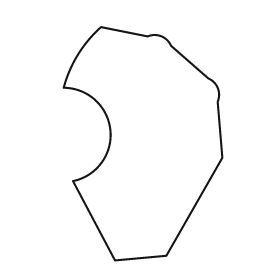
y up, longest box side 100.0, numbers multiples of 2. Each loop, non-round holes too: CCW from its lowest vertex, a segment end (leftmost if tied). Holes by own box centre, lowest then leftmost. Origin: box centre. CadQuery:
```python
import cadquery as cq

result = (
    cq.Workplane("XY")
    .moveTo(-12.0, -50.0)
    .lineTo(10.0, -48.0)
    .lineTo(34.0, -6.0)
    .lineTo(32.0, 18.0)
    .threePointArc((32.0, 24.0), (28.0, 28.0))
    .lineTo(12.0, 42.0)
    .threePointArc((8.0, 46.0), (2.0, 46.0))
    .lineTo(-18.0, 50.0)
    .threePointArc((-28.0, 38.0), (-34.0, 24.0))
    .threePointArc((-14.0, 6.0), (-30.0, -16.0))
    .close()
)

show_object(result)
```